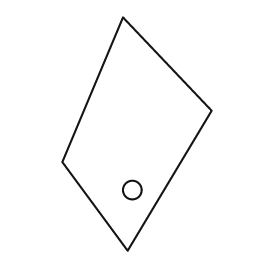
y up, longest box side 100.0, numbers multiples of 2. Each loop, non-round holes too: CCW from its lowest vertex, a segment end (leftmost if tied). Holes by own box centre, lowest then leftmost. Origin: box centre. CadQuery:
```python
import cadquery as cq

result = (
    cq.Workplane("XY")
    .moveTo(-4.0, -50.0)
    .lineTo(32.0, 10.0)
    .lineTo(-6.0, 50.0)
    .lineTo(-32.0, -12.0)
    .close()
    .moveTo(-2.0, -24.0)
    .circle(4.0)
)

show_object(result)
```